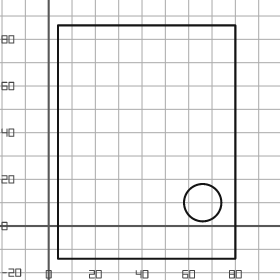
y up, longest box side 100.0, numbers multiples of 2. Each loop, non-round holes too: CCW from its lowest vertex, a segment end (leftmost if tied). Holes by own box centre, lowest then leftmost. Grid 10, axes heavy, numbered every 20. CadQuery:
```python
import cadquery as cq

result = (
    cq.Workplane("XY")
    .moveTo(4.0, -14.0)
    .lineTo(80.0, -14.0)
    .lineTo(80.0, 86.0)
    .lineTo(4.0, 86.0)
    .close()
    .moveTo(66.0, 10.0)
    .circle(8.0)
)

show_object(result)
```